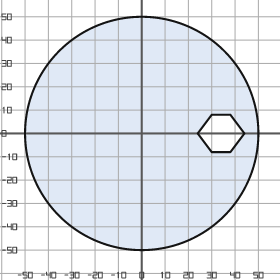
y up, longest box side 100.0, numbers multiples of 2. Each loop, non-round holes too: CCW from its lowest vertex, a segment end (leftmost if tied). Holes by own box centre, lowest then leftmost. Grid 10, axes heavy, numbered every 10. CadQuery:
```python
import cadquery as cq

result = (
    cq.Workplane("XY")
    .moveTo(0.0, 0.0)
    .circle(50.0)
    .moveTo(30.0, -8.0)
    .lineTo(38.0, -8.0)
    .lineTo(44.0, 0.0)
    .lineTo(38.0, 8.0)
    .lineTo(30.0, 8.0)
    .lineTo(24.0, 0.0)
    .close()
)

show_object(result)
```